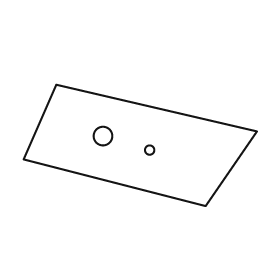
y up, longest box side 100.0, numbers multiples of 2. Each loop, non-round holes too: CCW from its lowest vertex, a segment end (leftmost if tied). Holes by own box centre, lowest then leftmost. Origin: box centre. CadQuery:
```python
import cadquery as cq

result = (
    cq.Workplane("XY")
    .moveTo(28.0, -26.0)
    .lineTo(50.0, 6.0)
    .lineTo(-36.0, 26.0)
    .lineTo(-50.0, -6.0)
    .close()
    .moveTo(4.0, -2.0)
    .circle(2.0)
    .moveTo(-16.0, 4.0)
    .circle(4.0)
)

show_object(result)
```